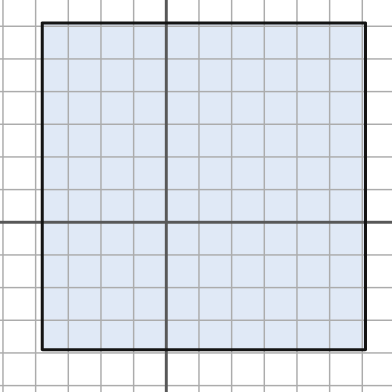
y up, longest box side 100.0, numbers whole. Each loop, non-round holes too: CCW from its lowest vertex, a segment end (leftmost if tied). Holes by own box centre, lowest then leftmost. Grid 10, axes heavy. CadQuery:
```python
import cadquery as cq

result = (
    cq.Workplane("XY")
    .moveTo(-38.0, -39.0)
    .lineTo(61.0, -39.0)
    .lineTo(61.0, 61.0)
    .lineTo(-38.0, 61.0)
    .close()
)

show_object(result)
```